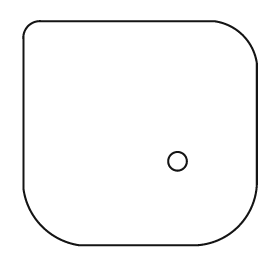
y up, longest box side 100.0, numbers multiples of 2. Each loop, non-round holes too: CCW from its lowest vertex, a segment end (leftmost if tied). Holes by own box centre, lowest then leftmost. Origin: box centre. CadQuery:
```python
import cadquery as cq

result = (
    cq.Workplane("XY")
    .moveTo(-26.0, -48.0)
    .lineTo(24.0, -48.0)
    .threePointArc((42.0, -40.0), (50.0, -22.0))
    .lineTo(50.0, 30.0)
    .threePointArc((44.0, 42.0), (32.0, 48.0))
    .lineTo(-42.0, 48.0)
    .threePointArc((-48.0, 46.0), (-50.0, 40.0))
    .lineTo(-50.0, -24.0)
    .threePointArc((-42.0, -40.0), (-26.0, -48.0))
    .close()
    .moveTo(16.0, -12.0)
    .circle(4.0)
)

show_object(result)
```